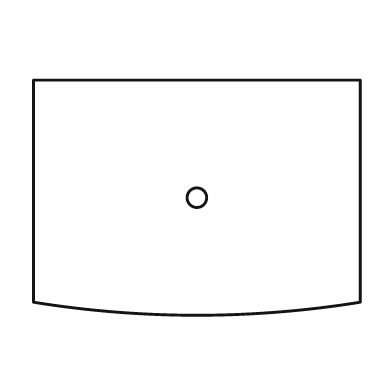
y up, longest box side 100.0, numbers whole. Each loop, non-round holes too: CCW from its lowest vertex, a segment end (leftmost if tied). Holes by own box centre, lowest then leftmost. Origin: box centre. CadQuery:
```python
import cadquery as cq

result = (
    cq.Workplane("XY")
    .moveTo(-50.0, -32.0)
    .threePointArc((0.0, -36.0), (50.0, -32.0))
    .lineTo(50.0, 36.0)
    .lineTo(-50.0, 36.0)
    .close()
    .moveTo(0.0, 0.0)
    .circle(3.0)
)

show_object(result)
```